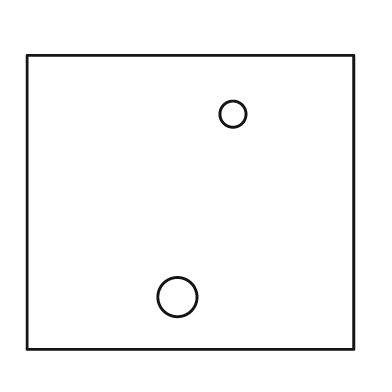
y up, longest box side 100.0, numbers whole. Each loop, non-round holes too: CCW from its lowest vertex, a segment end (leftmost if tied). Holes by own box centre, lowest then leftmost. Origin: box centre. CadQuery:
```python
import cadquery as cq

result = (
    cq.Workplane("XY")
    .moveTo(-50.0, -45.0)
    .lineTo(50.0, -45.0)
    .lineTo(50.0, 45.0)
    .lineTo(-50.0, 45.0)
    .close()
    .moveTo(-4.0, -29.0)
    .circle(6.0)
    .moveTo(13.0, 27.0)
    .circle(4.0)
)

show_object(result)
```